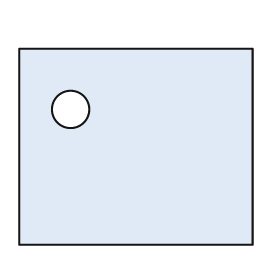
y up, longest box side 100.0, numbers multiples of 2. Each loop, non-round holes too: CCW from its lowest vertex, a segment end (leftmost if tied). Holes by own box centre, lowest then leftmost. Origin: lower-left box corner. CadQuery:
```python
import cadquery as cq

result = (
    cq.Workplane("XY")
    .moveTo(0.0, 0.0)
    .lineTo(100.0, 0.0)
    .lineTo(100.0, 84.0)
    .lineTo(0.0, 84.0)
    .close()
    .moveTo(22.0, 58.0)
    .circle(8.0)
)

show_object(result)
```